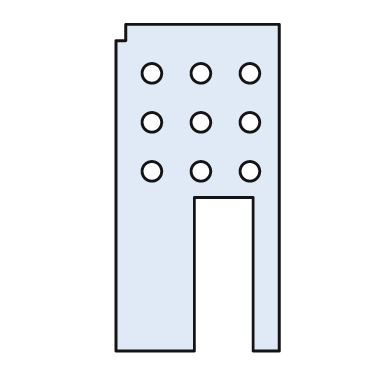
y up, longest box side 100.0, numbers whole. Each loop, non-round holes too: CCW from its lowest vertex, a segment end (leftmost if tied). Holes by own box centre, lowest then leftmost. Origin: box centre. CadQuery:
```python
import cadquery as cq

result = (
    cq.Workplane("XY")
    .moveTo(-25.0, -50.0)
    .lineTo(-1.0, -50.0)
    .lineTo(-1.0, -3.0)
    .lineTo(17.0, -3.0)
    .lineTo(17.0, -50.0)
    .lineTo(25.0, -50.0)
    .lineTo(25.0, 50.0)
    .lineTo(-22.0, 50.0)
    .lineTo(-22.0, 45.0)
    .lineTo(-25.0, 45.0)
    .close()
    .moveTo(-14.0, 5.0)
    .circle(3.0)
    .moveTo(1.0, 5.0)
    .circle(3.0)
    .moveTo(16.0, 5.0)
    .circle(3.0)
    .moveTo(-14.0, 20.0)
    .circle(3.0)
    .moveTo(1.0, 20.0)
    .circle(3.0)
    .moveTo(16.0, 20.0)
    .circle(3.0)
    .moveTo(-14.0, 35.0)
    .circle(3.0)
    .moveTo(1.0, 35.0)
    .circle(3.0)
    .moveTo(16.0, 35.0)
    .circle(3.0)
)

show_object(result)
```